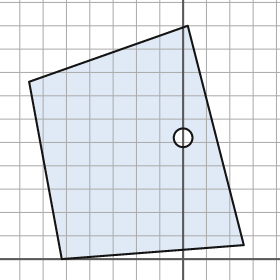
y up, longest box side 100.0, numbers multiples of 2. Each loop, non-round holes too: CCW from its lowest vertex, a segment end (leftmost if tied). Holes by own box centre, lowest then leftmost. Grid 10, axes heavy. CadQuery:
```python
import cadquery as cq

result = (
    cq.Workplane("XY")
    .moveTo(-52.0, 0.0)
    .lineTo(26.0, 6.0)
    .lineTo(2.0, 100.0)
    .lineTo(-66.0, 76.0)
    .close()
    .moveTo(0.0, 52.0)
    .circle(4.0)
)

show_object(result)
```